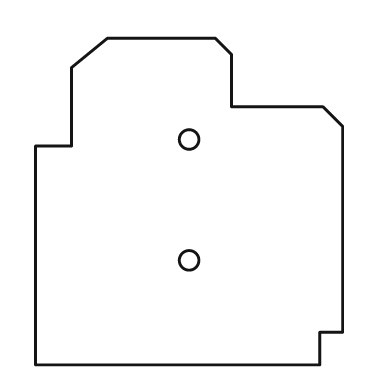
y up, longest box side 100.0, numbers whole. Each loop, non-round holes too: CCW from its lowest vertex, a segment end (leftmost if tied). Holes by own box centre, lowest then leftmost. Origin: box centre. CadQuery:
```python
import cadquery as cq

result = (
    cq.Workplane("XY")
    .moveTo(-47.0, -50.0)
    .lineTo(40.0, -50.0)
    .lineTo(40.0, -40.0)
    .lineTo(47.0, -40.0)
    .lineTo(47.0, 23.0)
    .lineTo(41.0, 29.0)
    .lineTo(13.0, 29.0)
    .lineTo(13.0, 45.0)
    .lineTo(8.0, 50.0)
    .lineTo(-25.0, 50.0)
    .lineTo(-36.0, 41.0)
    .lineTo(-36.0, 17.0)
    .lineTo(-47.0, 17.0)
    .close()
    .moveTo(0.0, -18.0)
    .circle(3.0)
    .moveTo(0.0, 19.0)
    .circle(3.0)
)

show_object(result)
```